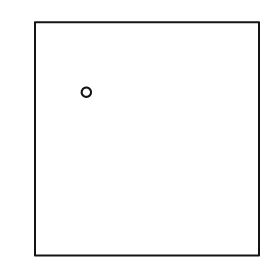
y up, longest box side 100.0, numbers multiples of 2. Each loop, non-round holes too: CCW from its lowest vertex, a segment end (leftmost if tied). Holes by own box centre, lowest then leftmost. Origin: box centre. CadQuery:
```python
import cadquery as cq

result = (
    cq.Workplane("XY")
    .moveTo(-48.0, -50.0)
    .lineTo(48.0, -50.0)
    .lineTo(48.0, 50.0)
    .lineTo(-48.0, 50.0)
    .close()
    .moveTo(-26.0, 20.0)
    .circle(2.0)
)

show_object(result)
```